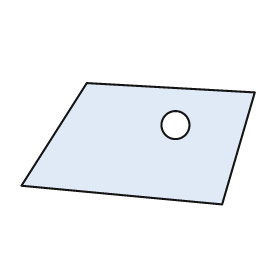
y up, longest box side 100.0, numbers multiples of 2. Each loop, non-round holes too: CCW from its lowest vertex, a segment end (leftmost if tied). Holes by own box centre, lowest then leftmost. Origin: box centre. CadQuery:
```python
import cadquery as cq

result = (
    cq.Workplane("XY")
    .moveTo(36.0, -26.0)
    .lineTo(50.0, 22.0)
    .lineTo(-22.0, 26.0)
    .lineTo(-50.0, -18.0)
    .close()
    .moveTo(16.0, 8.0)
    .circle(6.0)
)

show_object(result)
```